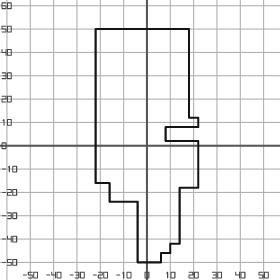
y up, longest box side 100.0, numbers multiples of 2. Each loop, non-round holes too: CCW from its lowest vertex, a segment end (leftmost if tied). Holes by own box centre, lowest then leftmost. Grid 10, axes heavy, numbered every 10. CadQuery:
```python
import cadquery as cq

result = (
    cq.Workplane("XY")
    .moveTo(-4.0, -50.0)
    .lineTo(6.0, -50.0)
    .lineTo(6.0, -46.0)
    .lineTo(10.0, -46.0)
    .lineTo(10.0, -42.0)
    .lineTo(14.0, -42.0)
    .lineTo(14.0, -18.0)
    .lineTo(22.0, -18.0)
    .lineTo(22.0, 2.0)
    .lineTo(8.0, 2.0)
    .lineTo(8.0, 8.0)
    .lineTo(22.0, 8.0)
    .lineTo(22.0, 12.0)
    .lineTo(18.0, 12.0)
    .lineTo(18.0, 50.0)
    .lineTo(-22.0, 50.0)
    .lineTo(-22.0, -16.0)
    .lineTo(-16.0, -16.0)
    .lineTo(-16.0, -24.0)
    .lineTo(-4.0, -24.0)
    .close()
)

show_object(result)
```